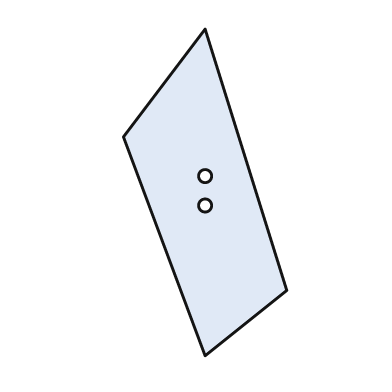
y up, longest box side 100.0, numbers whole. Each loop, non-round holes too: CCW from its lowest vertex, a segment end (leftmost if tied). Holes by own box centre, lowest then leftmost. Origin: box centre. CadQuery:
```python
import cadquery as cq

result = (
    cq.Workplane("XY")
    .moveTo(0.0, -50.0)
    .lineTo(25.0, -30.0)
    .lineTo(0.0, 50.0)
    .lineTo(-25.0, 17.0)
    .close()
    .moveTo(0.0, -4.0)
    .circle(2.0)
    .moveTo(0.0, 5.0)
    .circle(2.0)
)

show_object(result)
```